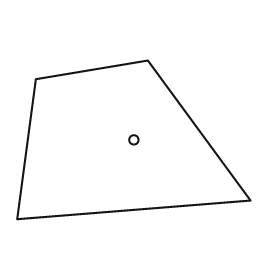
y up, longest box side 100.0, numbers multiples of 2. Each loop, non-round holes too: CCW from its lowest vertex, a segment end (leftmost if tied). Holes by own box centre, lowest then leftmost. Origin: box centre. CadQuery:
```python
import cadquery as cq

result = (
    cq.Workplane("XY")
    .moveTo(-50.0, -34.0)
    .lineTo(50.0, -26.0)
    .lineTo(6.0, 34.0)
    .lineTo(-42.0, 26.0)
    .close()
    .moveTo(0.0, 0.0)
    .circle(2.0)
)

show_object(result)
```